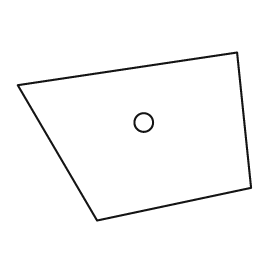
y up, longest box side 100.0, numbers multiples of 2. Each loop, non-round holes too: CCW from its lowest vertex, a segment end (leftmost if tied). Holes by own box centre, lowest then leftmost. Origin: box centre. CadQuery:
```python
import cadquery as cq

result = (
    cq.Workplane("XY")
    .moveTo(-16.0, -36.0)
    .lineTo(50.0, -22.0)
    .lineTo(44.0, 36.0)
    .lineTo(-50.0, 22.0)
    .close()
    .moveTo(4.0, 6.0)
    .circle(4.0)
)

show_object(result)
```